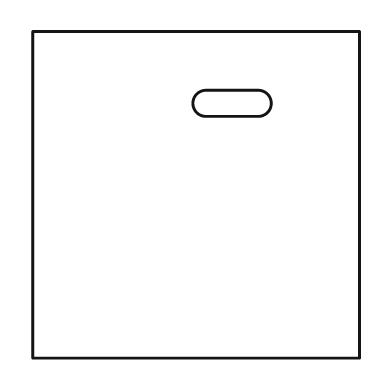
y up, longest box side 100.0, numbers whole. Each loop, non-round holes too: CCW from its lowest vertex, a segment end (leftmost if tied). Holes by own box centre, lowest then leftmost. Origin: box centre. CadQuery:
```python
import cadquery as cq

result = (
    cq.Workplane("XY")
    .moveTo(-50.0, -50.0)
    .lineTo(50.0, -50.0)
    .lineTo(50.0, 50.0)
    .lineTo(-50.0, 50.0)
    .close()
    .moveTo(3.0, 24.0)
    .lineTo(19.0, 24.0)
    .threePointArc((23.0, 28.0), (19.0, 32.0))
    .lineTo(3.0, 32.0)
    .threePointArc((-1.0, 28.0), (3.0, 24.0))
    .close()
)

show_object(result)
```